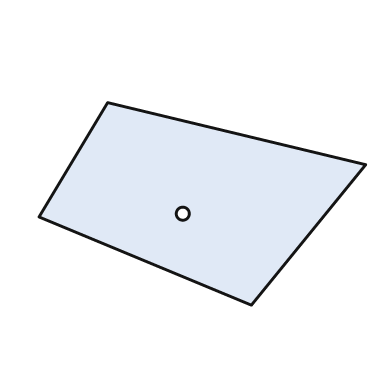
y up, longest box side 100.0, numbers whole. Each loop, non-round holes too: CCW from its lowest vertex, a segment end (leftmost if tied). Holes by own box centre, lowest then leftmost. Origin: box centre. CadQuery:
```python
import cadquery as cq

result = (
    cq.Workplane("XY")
    .moveTo(15.0, -31.0)
    .lineTo(50.0, 12.0)
    .lineTo(-29.0, 31.0)
    .lineTo(-50.0, -4.0)
    .close()
    .moveTo(-6.0, -3.0)
    .circle(2.0)
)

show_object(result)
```